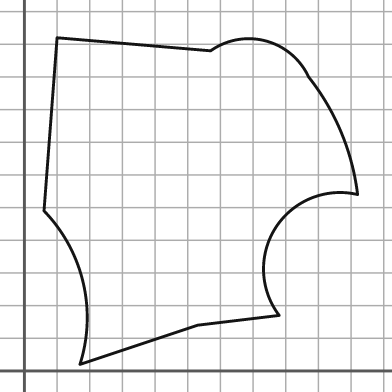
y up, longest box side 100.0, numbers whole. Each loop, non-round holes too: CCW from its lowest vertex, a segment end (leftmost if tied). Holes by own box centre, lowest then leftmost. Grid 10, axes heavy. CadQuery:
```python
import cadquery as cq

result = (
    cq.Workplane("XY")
    .moveTo(17.0, 2.0)
    .lineTo(53.0, 14.0)
    .lineTo(78.0, 17.0)
    .threePointArc((77.0, 44.0), (102.0, 54.0))
    .threePointArc((97.0, 73.0), (87.0, 90.0))
    .threePointArc((74.0, 101.0), (57.0, 98.0))
    .lineTo(10.0, 102.0)
    .lineTo(6.0, 49.0)
    .threePointArc((18.0, 27.0), (17.0, 2.0))
    .close()
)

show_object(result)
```